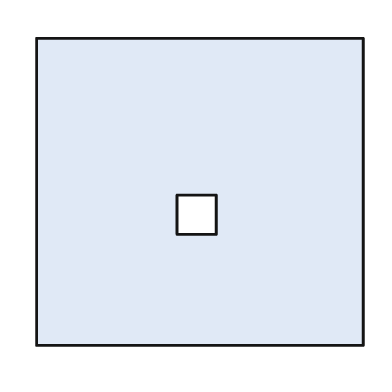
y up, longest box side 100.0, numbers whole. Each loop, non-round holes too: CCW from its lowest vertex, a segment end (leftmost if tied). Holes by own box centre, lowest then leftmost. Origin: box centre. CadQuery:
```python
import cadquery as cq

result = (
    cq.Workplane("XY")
    .moveTo(-50.0, -47.0)
    .lineTo(50.0, -47.0)
    .lineTo(50.0, 47.0)
    .lineTo(-50.0, 47.0)
    .close()
    .moveTo(-7.0, -13.0)
    .lineTo(5.0, -13.0)
    .lineTo(5.0, -1.0)
    .lineTo(-7.0, -1.0)
    .close()
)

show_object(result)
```